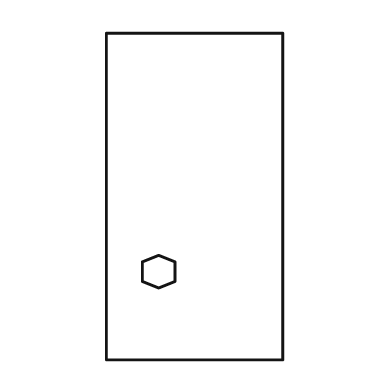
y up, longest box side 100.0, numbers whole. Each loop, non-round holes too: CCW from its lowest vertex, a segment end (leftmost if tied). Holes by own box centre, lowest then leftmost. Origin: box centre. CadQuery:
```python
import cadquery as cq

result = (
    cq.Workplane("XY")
    .moveTo(-27.0, -50.0)
    .lineTo(27.0, -50.0)
    .lineTo(27.0, 50.0)
    .lineTo(-27.0, 50.0)
    .close()
    .moveTo(-11.0, -28.0)
    .lineTo(-6.0, -26.0)
    .lineTo(-6.0, -20.0)
    .lineTo(-11.0, -18.0)
    .lineTo(-16.0, -20.0)
    .lineTo(-16.0, -26.0)
    .close()
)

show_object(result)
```